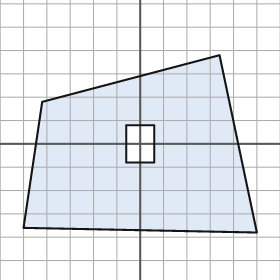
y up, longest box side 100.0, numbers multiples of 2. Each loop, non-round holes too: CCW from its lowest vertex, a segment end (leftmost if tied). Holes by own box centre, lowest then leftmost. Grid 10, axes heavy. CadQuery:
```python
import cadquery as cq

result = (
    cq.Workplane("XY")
    .moveTo(50.0, -38.0)
    .lineTo(34.0, 38.0)
    .lineTo(-42.0, 18.0)
    .lineTo(-50.0, -36.0)
    .close()
    .moveTo(-6.0, -8.0)
    .lineTo(6.0, -8.0)
    .lineTo(6.0, 8.0)
    .lineTo(-6.0, 8.0)
    .close()
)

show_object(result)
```